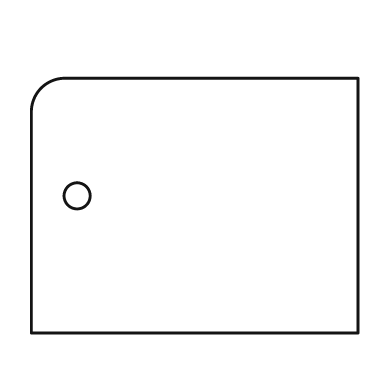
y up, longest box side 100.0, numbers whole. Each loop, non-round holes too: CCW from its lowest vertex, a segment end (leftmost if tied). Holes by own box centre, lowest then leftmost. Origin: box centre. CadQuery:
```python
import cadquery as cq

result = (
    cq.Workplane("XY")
    .moveTo(-50.0, -39.0)
    .lineTo(50.0, -39.0)
    .lineTo(50.0, 39.0)
    .lineTo(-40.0, 39.0)
    .threePointArc((-47.0, 36.0), (-50.0, 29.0))
    .close()
    .moveTo(-36.0, 3.0)
    .circle(4.0)
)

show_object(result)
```